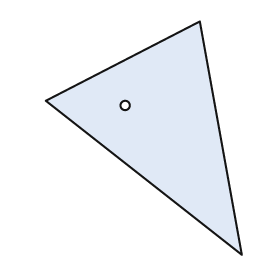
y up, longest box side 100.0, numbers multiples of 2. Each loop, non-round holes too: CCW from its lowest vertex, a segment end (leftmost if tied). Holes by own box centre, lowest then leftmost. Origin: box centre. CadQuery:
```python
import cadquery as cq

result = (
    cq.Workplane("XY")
    .moveTo(42.0, -50.0)
    .lineTo(24.0, 50.0)
    .lineTo(-42.0, 16.0)
    .close()
    .moveTo(-8.0, 14.0)
    .circle(2.0)
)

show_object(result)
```